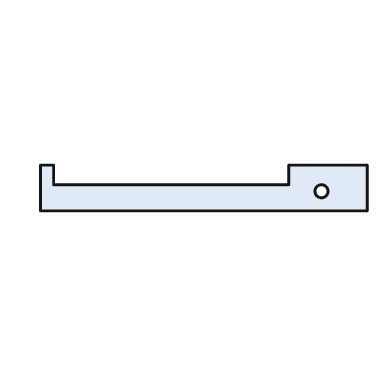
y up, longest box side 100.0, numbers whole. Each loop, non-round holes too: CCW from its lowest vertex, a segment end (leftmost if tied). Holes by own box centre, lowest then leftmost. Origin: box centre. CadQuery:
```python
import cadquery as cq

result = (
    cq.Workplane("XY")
    .moveTo(-50.0, -7.0)
    .lineTo(50.0, -7.0)
    .lineTo(50.0, 7.0)
    .lineTo(26.0, 7.0)
    .lineTo(26.0, 1.0)
    .lineTo(-46.0, 1.0)
    .lineTo(-46.0, 7.0)
    .lineTo(-50.0, 7.0)
    .close()
    .moveTo(36.0, -1.0)
    .circle(2.0)
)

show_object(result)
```